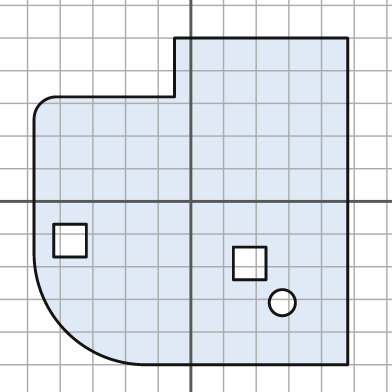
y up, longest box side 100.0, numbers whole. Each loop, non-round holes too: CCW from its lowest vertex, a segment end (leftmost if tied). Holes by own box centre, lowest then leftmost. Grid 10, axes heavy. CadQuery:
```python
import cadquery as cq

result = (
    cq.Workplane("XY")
    .moveTo(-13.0, -50.0)
    .lineTo(48.0, -50.0)
    .lineTo(48.0, 50.0)
    .lineTo(-5.0, 50.0)
    .lineTo(-5.0, 32.0)
    .lineTo(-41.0, 32.0)
    .threePointArc((-46.0, 30.0), (-48.0, 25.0))
    .lineTo(-48.0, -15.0)
    .threePointArc((-38.0, -40.0), (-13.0, -50.0))
    .close()
    .moveTo(28.0, -31.0)
    .circle(4.0)
    .moveTo(13.0, -24.0)
    .lineTo(23.0, -24.0)
    .lineTo(23.0, -14.0)
    .lineTo(13.0, -14.0)
    .close()
    .moveTo(-42.0, -17.0)
    .lineTo(-32.0, -17.0)
    .lineTo(-32.0, -7.0)
    .lineTo(-42.0, -7.0)
    .close()
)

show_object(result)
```